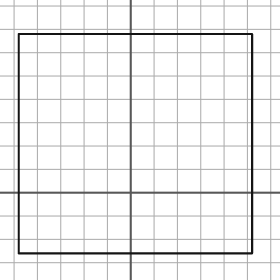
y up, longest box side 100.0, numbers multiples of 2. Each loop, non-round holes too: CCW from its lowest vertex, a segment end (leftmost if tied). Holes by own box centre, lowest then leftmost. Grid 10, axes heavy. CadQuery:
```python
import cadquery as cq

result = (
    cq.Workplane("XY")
    .moveTo(-48.0, -26.0)
    .lineTo(52.0, -26.0)
    .lineTo(52.0, 68.0)
    .lineTo(-48.0, 68.0)
    .close()
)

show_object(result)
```